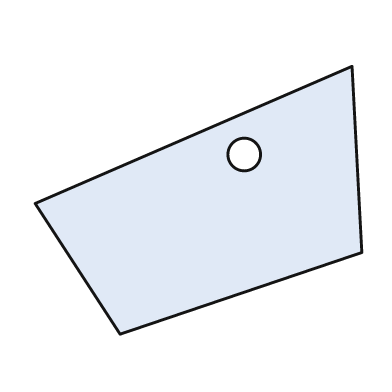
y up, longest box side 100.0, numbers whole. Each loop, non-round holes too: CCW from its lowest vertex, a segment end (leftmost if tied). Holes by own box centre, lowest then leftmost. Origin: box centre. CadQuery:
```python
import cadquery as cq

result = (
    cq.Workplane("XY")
    .moveTo(-24.0, -41.0)
    .lineTo(50.0, -16.0)
    .lineTo(47.0, 41.0)
    .lineTo(-50.0, -1.0)
    .close()
    .moveTo(14.0, 14.0)
    .circle(5.0)
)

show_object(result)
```